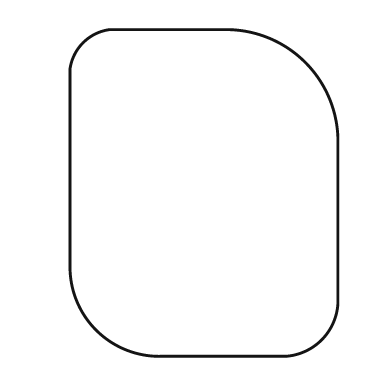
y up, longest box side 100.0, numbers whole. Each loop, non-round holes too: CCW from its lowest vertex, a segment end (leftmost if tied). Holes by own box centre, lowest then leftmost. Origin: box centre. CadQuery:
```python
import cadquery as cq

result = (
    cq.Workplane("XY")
    .moveTo(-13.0, -50.0)
    .lineTo(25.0, -50.0)
    .threePointArc((36.0, -45.0), (41.0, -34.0))
    .lineTo(41.0, 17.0)
    .threePointArc((31.0, 40.0), (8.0, 50.0))
    .lineTo(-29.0, 50.0)
    .threePointArc((-37.0, 46.0), (-41.0, 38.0))
    .lineTo(-41.0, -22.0)
    .threePointArc((-33.0, -42.0), (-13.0, -50.0))
    .close()
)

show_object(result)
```